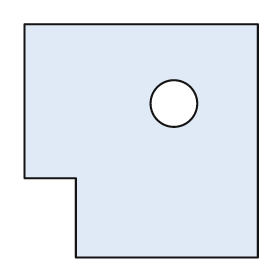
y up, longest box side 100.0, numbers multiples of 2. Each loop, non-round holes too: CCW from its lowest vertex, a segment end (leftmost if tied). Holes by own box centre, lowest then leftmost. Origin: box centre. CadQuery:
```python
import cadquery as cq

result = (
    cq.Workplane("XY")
    .moveTo(-28.0, -50.0)
    .lineTo(50.0, -50.0)
    .lineTo(50.0, 50.0)
    .lineTo(-50.0, 50.0)
    .lineTo(-50.0, -16.0)
    .lineTo(-28.0, -16.0)
    .close()
    .moveTo(14.0, 16.0)
    .circle(10.0)
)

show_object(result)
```